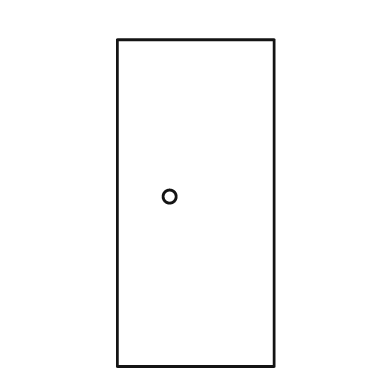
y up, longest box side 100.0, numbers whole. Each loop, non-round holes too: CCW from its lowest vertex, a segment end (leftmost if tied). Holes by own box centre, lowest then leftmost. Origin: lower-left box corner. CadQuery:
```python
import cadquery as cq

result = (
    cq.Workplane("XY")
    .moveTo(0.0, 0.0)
    .lineTo(48.0, 0.0)
    .lineTo(48.0, 100.0)
    .lineTo(0.0, 100.0)
    .close()
    .moveTo(16.0, 52.0)
    .circle(2.0)
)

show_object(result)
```